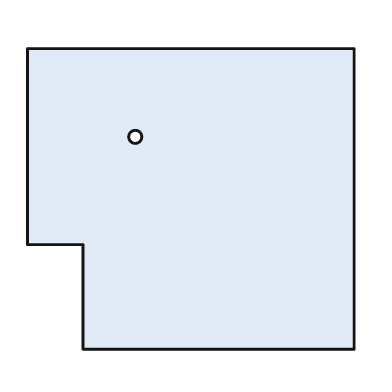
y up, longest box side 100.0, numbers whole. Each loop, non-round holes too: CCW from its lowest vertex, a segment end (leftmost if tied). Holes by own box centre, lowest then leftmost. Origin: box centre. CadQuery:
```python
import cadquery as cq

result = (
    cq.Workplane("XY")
    .moveTo(-33.0, -46.0)
    .lineTo(50.0, -46.0)
    .lineTo(50.0, 46.0)
    .lineTo(-50.0, 46.0)
    .lineTo(-50.0, -14.0)
    .lineTo(-33.0, -14.0)
    .close()
    .moveTo(-17.0, 19.0)
    .circle(2.0)
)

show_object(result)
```